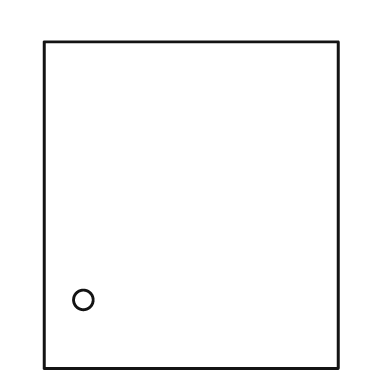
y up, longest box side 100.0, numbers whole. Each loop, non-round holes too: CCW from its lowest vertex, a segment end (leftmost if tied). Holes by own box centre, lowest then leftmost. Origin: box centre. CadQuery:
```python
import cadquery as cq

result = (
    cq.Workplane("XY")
    .moveTo(-45.0, -50.0)
    .lineTo(45.0, -50.0)
    .lineTo(45.0, 50.0)
    .lineTo(-45.0, 50.0)
    .close()
    .moveTo(-33.0, -29.0)
    .circle(3.0)
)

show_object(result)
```